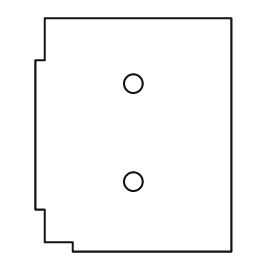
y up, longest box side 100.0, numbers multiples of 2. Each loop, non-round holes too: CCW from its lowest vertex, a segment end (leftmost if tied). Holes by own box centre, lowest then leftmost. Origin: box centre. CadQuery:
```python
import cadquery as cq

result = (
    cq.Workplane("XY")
    .moveTo(-26.0, -50.0)
    .lineTo(42.0, -50.0)
    .lineTo(42.0, 50.0)
    .lineTo(-38.0, 50.0)
    .lineTo(-38.0, 32.0)
    .lineTo(-42.0, 32.0)
    .lineTo(-42.0, -32.0)
    .lineTo(-38.0, -32.0)
    .lineTo(-38.0, -46.0)
    .lineTo(-26.0, -46.0)
    .close()
    .moveTo(0.0, -20.0)
    .circle(4.0)
    .moveTo(0.0, 22.0)
    .circle(4.0)
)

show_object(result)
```